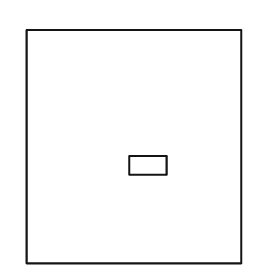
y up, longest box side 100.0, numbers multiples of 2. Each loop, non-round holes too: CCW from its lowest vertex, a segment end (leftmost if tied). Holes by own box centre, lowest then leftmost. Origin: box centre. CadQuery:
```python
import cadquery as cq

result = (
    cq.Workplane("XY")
    .moveTo(-46.0, -50.0)
    .lineTo(46.0, -50.0)
    .lineTo(46.0, 50.0)
    .lineTo(-46.0, 50.0)
    .close()
    .moveTo(-2.0, -12.0)
    .lineTo(14.0, -12.0)
    .lineTo(14.0, -4.0)
    .lineTo(-2.0, -4.0)
    .close()
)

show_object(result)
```